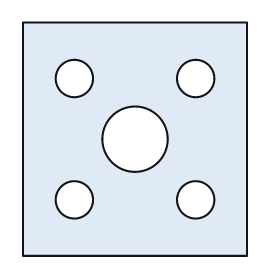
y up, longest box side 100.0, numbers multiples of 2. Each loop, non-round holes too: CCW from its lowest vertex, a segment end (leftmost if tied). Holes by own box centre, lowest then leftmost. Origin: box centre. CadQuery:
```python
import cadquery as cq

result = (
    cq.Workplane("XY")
    .moveTo(-48.0, -50.0)
    .lineTo(48.0, -50.0)
    .lineTo(48.0, 50.0)
    .lineTo(-48.0, 50.0)
    .close()
    .moveTo(-26.0, -26.0)
    .circle(8.0)
    .moveTo(26.0, -26.0)
    .circle(8.0)
    .moveTo(0.0, 0.0)
    .circle(14.0)
    .moveTo(-26.0, 26.0)
    .circle(8.0)
    .moveTo(26.0, 26.0)
    .circle(8.0)
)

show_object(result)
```